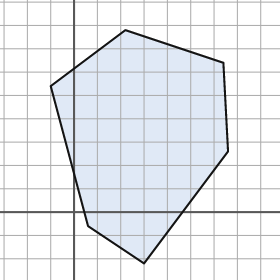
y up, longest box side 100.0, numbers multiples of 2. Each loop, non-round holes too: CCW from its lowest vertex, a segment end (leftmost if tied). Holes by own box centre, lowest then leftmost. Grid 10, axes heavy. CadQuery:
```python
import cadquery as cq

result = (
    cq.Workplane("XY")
    .moveTo(30.0, -22.0)
    .lineTo(66.0, 26.0)
    .lineTo(64.0, 64.0)
    .lineTo(22.0, 78.0)
    .lineTo(-10.0, 54.0)
    .lineTo(6.0, -6.0)
    .close()
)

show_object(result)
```